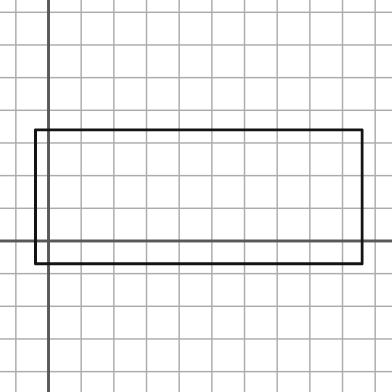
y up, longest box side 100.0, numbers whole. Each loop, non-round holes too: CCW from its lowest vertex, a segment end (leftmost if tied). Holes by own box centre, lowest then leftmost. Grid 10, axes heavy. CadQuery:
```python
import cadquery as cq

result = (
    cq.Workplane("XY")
    .moveTo(-4.0, -7.0)
    .lineTo(96.0, -7.0)
    .lineTo(96.0, 34.0)
    .lineTo(-4.0, 34.0)
    .close()
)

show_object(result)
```